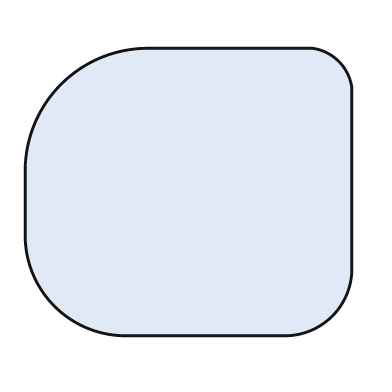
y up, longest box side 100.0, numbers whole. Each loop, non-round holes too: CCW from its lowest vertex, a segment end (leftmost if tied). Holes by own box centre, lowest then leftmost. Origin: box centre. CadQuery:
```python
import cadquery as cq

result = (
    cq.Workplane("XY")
    .moveTo(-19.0, -44.0)
    .lineTo(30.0, -44.0)
    .threePointArc((44.0, -38.0), (50.0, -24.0))
    .lineTo(50.0, 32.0)
    .threePointArc((46.0, 40.0), (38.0, 44.0))
    .lineTo(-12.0, 44.0)
    .threePointArc((-39.0, 33.0), (-50.0, 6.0))
    .lineTo(-50.0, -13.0)
    .threePointArc((-41.0, -35.0), (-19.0, -44.0))
    .close()
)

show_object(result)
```